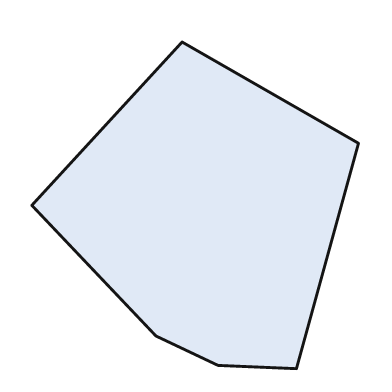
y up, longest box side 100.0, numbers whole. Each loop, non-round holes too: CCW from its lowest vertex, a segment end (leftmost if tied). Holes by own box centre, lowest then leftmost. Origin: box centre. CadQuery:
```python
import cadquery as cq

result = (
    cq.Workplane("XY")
    .moveTo(31.0, -50.0)
    .lineTo(50.0, 19.0)
    .lineTo(-4.0, 50.0)
    .lineTo(-50.0, 0.0)
    .lineTo(-12.0, -40.0)
    .lineTo(7.0, -49.0)
    .close()
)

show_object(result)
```